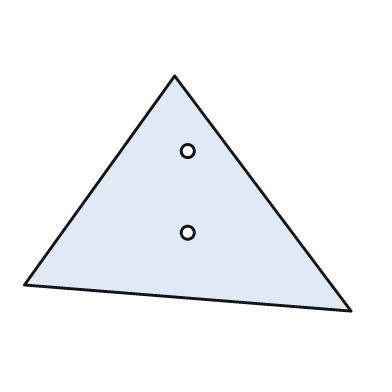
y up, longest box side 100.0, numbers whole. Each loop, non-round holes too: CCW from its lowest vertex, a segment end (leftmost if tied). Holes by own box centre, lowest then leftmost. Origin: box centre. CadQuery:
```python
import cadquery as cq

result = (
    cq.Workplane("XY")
    .moveTo(50.0, -36.0)
    .lineTo(-4.0, 36.0)
    .lineTo(-50.0, -28.0)
    .close()
    .moveTo(0.0, -12.0)
    .circle(2.0)
    .moveTo(0.0, 13.0)
    .circle(2.0)
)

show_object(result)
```